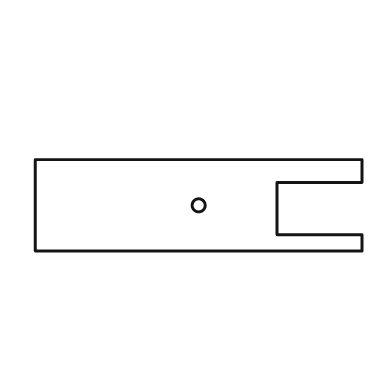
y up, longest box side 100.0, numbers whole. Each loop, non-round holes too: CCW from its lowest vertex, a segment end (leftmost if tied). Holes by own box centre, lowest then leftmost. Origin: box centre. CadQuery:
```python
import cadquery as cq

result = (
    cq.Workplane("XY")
    .moveTo(-50.0, -14.0)
    .lineTo(50.0, -14.0)
    .lineTo(50.0, -9.0)
    .lineTo(24.0, -9.0)
    .lineTo(24.0, 7.0)
    .lineTo(50.0, 7.0)
    .lineTo(50.0, 14.0)
    .lineTo(-50.0, 14.0)
    .close()
    .moveTo(0.0, 0.0)
    .circle(2.0)
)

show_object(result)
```